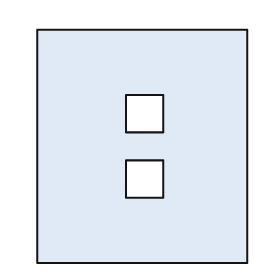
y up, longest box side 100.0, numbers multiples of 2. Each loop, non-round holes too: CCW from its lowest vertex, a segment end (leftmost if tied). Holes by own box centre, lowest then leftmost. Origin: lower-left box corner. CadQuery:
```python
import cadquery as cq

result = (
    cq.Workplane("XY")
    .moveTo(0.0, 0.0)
    .lineTo(90.0, 0.0)
    .lineTo(90.0, 100.0)
    .lineTo(0.0, 100.0)
    .close()
    .moveTo(38.0, 28.0)
    .lineTo(54.0, 28.0)
    .lineTo(54.0, 44.0)
    .lineTo(38.0, 44.0)
    .close()
    .moveTo(38.0, 56.0)
    .lineTo(54.0, 56.0)
    .lineTo(54.0, 72.0)
    .lineTo(38.0, 72.0)
    .close()
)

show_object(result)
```